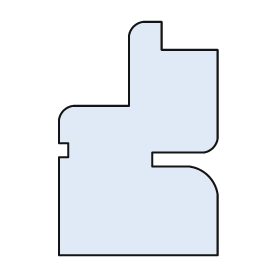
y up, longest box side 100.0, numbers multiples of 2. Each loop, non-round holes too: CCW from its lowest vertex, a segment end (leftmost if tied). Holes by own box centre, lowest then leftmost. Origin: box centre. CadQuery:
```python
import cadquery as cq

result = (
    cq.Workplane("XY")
    .moveTo(-34.0, -50.0)
    .lineTo(34.0, -50.0)
    .lineTo(34.0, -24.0)
    .threePointArc((30.0, -16.0), (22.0, -12.0))
    .lineTo(6.0, -12.0)
    .lineTo(6.0, -6.0)
    .lineTo(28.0, -6.0)
    .threePointArc((32.0, -4.0), (34.0, 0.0))
    .lineTo(34.0, 38.0)
    .lineTo(10.0, 38.0)
    .lineTo(10.0, 50.0)
    .lineTo(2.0, 50.0)
    .threePointArc((-2.0, 48.0), (-4.0, 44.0))
    .lineTo(-4.0, 14.0)
    .lineTo(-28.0, 14.0)
    .threePointArc((-32.0, 12.0), (-34.0, 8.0))
    .lineTo(-34.0, -2.0)
    .lineTo(-30.0, -2.0)
    .lineTo(-30.0, -8.0)
    .lineTo(-34.0, -8.0)
    .close()
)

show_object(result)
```